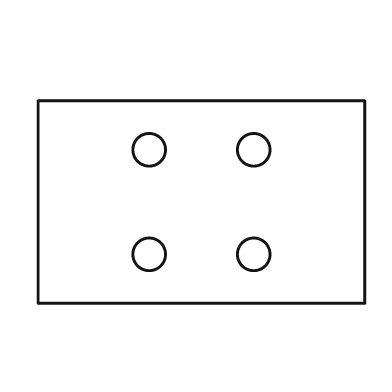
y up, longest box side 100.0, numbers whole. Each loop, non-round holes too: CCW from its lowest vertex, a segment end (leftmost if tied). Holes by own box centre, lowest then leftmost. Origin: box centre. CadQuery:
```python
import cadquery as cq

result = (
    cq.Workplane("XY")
    .moveTo(-50.0, -31.0)
    .lineTo(50.0, -31.0)
    .lineTo(50.0, 31.0)
    .lineTo(-50.0, 31.0)
    .close()
    .moveTo(-16.0, -16.0)
    .circle(5.0)
    .moveTo(16.0, -16.0)
    .circle(5.0)
    .moveTo(-16.0, 16.0)
    .circle(5.0)
    .moveTo(16.0, 16.0)
    .circle(5.0)
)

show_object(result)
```